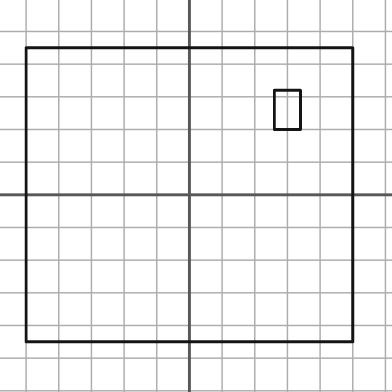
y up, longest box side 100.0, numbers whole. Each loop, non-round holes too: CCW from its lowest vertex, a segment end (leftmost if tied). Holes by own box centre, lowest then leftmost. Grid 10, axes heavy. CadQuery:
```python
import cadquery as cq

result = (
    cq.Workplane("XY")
    .moveTo(-50.0, -45.0)
    .lineTo(50.0, -45.0)
    .lineTo(50.0, 45.0)
    .lineTo(-50.0, 45.0)
    .close()
    .moveTo(26.0, 20.0)
    .lineTo(34.0, 20.0)
    .lineTo(34.0, 32.0)
    .lineTo(26.0, 32.0)
    .close()
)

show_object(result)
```